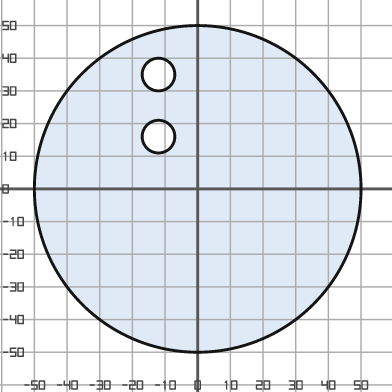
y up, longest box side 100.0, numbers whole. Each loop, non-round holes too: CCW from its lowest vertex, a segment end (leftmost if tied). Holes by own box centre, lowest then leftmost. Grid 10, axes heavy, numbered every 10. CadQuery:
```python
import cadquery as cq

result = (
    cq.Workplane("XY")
    .moveTo(0.0, 0.0)
    .circle(50.0)
    .moveTo(-12.0, 16.0)
    .circle(5.0)
    .moveTo(-12.0, 35.0)
    .circle(5.0)
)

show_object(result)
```